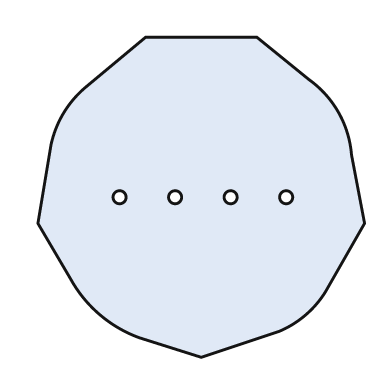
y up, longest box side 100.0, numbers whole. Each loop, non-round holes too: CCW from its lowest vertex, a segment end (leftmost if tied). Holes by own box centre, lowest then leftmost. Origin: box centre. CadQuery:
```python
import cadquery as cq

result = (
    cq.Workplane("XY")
    .moveTo(0.0, -49.0)
    .lineTo(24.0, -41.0)
    .threePointArc((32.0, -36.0), (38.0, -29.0))
    .lineTo(50.0, -8.0)
    .lineTo(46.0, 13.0)
    .threePointArc((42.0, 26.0), (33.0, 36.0))
    .lineTo(17.0, 49.0)
    .lineTo(-17.0, 49.0)
    .lineTo(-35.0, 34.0)
    .threePointArc((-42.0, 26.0), (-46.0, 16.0))
    .lineTo(-50.0, -8.0)
    .lineTo(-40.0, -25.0)
    .threePointArc((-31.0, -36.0), (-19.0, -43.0))
    .close()
    .moveTo(-25.0, 0.0)
    .circle(2.0)
    .moveTo(-8.0, 0.0)
    .circle(2.0)
    .moveTo(9.0, 0.0)
    .circle(2.0)
    .moveTo(26.0, 0.0)
    .circle(2.0)
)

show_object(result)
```